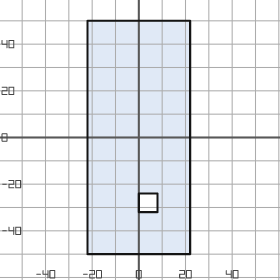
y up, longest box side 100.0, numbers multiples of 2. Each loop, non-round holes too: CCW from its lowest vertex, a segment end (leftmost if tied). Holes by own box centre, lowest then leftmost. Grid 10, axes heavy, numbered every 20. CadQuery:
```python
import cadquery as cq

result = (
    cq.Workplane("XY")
    .moveTo(-22.0, -50.0)
    .lineTo(22.0, -50.0)
    .lineTo(22.0, 50.0)
    .lineTo(-22.0, 50.0)
    .close()
    .moveTo(0.0, -32.0)
    .lineTo(8.0, -32.0)
    .lineTo(8.0, -24.0)
    .lineTo(0.0, -24.0)
    .close()
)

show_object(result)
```